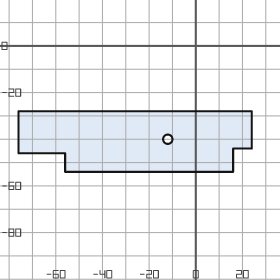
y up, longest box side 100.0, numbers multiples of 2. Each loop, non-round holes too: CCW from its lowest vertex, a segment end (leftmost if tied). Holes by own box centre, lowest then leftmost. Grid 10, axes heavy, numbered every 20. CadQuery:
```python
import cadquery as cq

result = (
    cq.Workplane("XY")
    .moveTo(-56.0, -54.0)
    .lineTo(16.0, -54.0)
    .lineTo(16.0, -44.0)
    .lineTo(24.0, -44.0)
    .lineTo(24.0, -28.0)
    .lineTo(-76.0, -28.0)
    .lineTo(-76.0, -46.0)
    .lineTo(-56.0, -46.0)
    .close()
    .moveTo(-12.0, -40.0)
    .circle(2.0)
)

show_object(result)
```